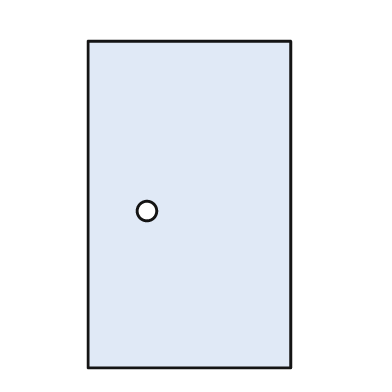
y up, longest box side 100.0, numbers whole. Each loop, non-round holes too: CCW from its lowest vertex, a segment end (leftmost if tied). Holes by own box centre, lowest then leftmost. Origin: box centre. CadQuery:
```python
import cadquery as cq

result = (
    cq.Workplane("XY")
    .moveTo(-31.0, -50.0)
    .lineTo(31.0, -50.0)
    .lineTo(31.0, 50.0)
    .lineTo(-31.0, 50.0)
    .close()
    .moveTo(-13.0, -2.0)
    .circle(3.0)
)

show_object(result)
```